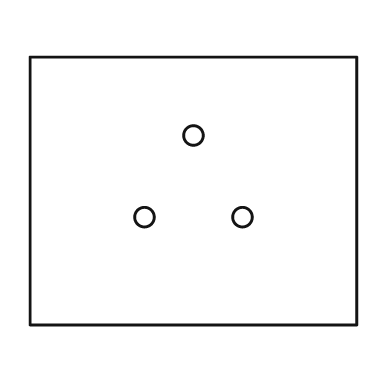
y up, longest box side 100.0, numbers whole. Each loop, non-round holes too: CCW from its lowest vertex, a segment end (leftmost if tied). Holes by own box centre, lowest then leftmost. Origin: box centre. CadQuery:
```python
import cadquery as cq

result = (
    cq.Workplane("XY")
    .moveTo(-50.0, -41.0)
    .lineTo(50.0, -41.0)
    .lineTo(50.0, 41.0)
    .lineTo(-50.0, 41.0)
    .close()
    .moveTo(-15.0, -8.0)
    .circle(3.0)
    .moveTo(15.0, -8.0)
    .circle(3.0)
    .moveTo(0.0, 17.0)
    .circle(3.0)
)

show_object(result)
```